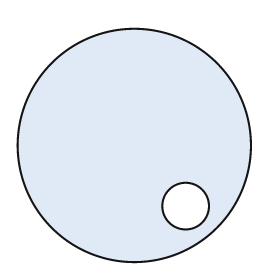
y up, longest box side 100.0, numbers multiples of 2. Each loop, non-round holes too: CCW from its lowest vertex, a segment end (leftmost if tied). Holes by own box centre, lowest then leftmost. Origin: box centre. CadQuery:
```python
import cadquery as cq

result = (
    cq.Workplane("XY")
    .moveTo(0.0, 0.0)
    .circle(50.0)
    .moveTo(22.0, -26.0)
    .circle(10.0)
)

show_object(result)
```